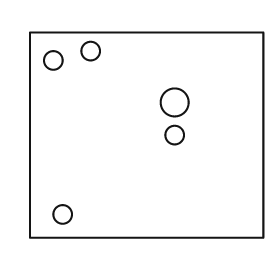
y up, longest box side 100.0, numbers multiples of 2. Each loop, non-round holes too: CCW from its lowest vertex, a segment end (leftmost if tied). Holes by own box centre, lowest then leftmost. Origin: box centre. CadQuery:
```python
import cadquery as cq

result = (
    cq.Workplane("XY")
    .moveTo(-50.0, -44.0)
    .lineTo(50.0, -44.0)
    .lineTo(50.0, 44.0)
    .lineTo(-50.0, 44.0)
    .close()
    .moveTo(-36.0, -34.0)
    .circle(4.0)
    .moveTo(12.0, 0.0)
    .circle(4.0)
    .moveTo(12.0, 14.0)
    .circle(6.0)
    .moveTo(-40.0, 32.0)
    .circle(4.0)
    .moveTo(-24.0, 36.0)
    .circle(4.0)
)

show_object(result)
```